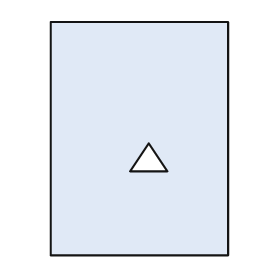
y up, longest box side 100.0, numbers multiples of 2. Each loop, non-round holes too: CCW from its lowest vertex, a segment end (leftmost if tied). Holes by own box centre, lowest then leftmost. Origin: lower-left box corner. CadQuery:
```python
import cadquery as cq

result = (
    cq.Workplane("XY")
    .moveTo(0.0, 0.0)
    .lineTo(76.0, 0.0)
    .lineTo(76.0, 100.0)
    .lineTo(0.0, 100.0)
    .close()
    .moveTo(34.0, 36.0)
    .lineTo(50.0, 36.0)
    .lineTo(42.0, 48.0)
    .close()
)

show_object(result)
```